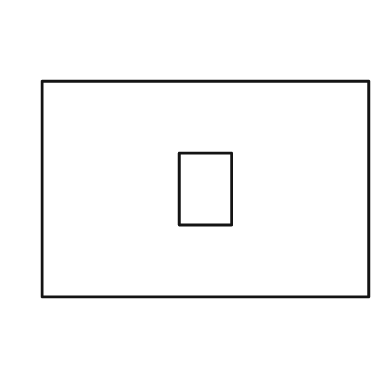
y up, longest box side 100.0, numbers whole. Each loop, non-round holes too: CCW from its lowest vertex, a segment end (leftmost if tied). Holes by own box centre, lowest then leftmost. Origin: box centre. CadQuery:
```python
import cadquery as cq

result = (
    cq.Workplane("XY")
    .moveTo(-50.0, -33.0)
    .lineTo(50.0, -33.0)
    .lineTo(50.0, 33.0)
    .lineTo(-50.0, 33.0)
    .close()
    .moveTo(-8.0, -11.0)
    .lineTo(8.0, -11.0)
    .lineTo(8.0, 11.0)
    .lineTo(-8.0, 11.0)
    .close()
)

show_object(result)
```